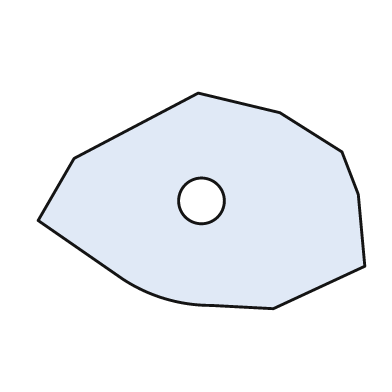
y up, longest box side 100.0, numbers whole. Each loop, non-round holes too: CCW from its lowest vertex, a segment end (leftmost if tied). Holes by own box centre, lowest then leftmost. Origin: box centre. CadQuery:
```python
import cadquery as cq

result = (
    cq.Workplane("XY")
    .moveTo(22.0, -33.0)
    .lineTo(50.0, -20.0)
    .lineTo(48.0, 2.0)
    .lineTo(43.0, 15.0)
    .lineTo(24.0, 27.0)
    .lineTo(-1.0, 33.0)
    .lineTo(-39.0, 13.0)
    .lineTo(-50.0, -6.0)
    .lineTo(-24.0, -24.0)
    .threePointArc((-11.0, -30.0), (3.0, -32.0))
    .close()
    .moveTo(0.0, 0.0)
    .circle(7.0)
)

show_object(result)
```